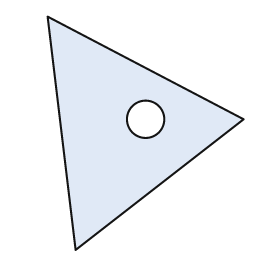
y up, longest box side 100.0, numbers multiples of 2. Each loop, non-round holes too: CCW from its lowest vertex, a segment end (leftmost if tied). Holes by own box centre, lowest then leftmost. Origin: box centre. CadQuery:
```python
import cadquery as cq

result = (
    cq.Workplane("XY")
    .moveTo(-30.0, -50.0)
    .lineTo(42.0, 6.0)
    .lineTo(-42.0, 50.0)
    .close()
    .moveTo(0.0, 6.0)
    .circle(8.0)
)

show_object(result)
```